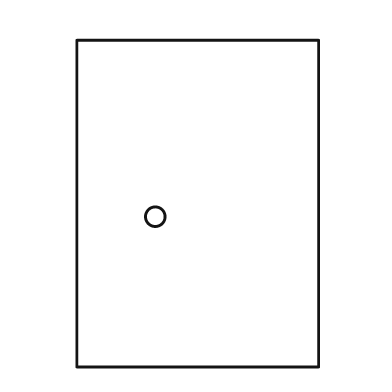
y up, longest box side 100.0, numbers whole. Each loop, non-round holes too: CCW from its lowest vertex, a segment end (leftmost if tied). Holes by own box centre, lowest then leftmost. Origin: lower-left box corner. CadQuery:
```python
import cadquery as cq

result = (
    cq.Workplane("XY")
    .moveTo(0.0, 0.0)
    .lineTo(74.0, 0.0)
    .lineTo(74.0, 100.0)
    .lineTo(0.0, 100.0)
    .close()
    .moveTo(24.0, 46.0)
    .circle(3.0)
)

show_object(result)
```